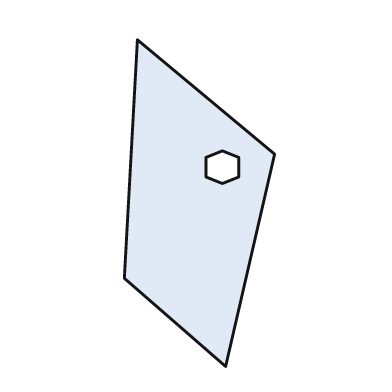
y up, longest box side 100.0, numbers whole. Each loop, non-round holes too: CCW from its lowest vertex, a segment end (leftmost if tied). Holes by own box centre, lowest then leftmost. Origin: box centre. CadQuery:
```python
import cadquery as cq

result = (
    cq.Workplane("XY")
    .moveTo(8.0, -50.0)
    .lineTo(23.0, 15.0)
    .lineTo(-19.0, 50.0)
    .lineTo(-23.0, -23.0)
    .close()
    .moveTo(7.0, 6.0)
    .lineTo(12.0, 8.0)
    .lineTo(12.0, 14.0)
    .lineTo(7.0, 16.0)
    .lineTo(2.0, 14.0)
    .lineTo(2.0, 8.0)
    .close()
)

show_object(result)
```